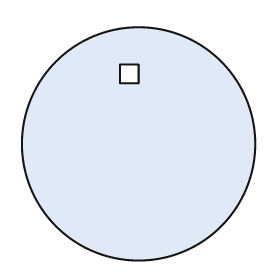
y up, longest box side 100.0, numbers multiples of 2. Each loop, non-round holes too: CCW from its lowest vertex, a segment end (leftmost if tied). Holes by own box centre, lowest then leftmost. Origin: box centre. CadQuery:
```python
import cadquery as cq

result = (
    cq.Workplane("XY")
    .moveTo(0.0, 0.0)
    .circle(50.0)
    .moveTo(-8.0, 26.0)
    .lineTo(0.0, 26.0)
    .lineTo(0.0, 34.0)
    .lineTo(-8.0, 34.0)
    .close()
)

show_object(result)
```